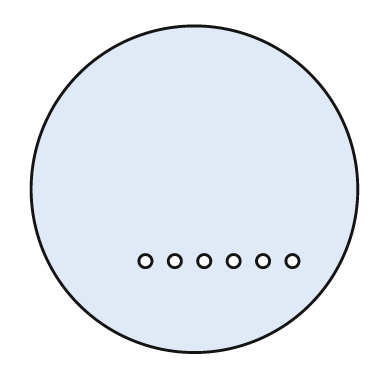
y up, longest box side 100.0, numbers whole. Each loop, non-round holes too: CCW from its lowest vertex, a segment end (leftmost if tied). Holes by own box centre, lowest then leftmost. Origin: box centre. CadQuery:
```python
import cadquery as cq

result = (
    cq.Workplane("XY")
    .moveTo(0.0, 0.0)
    .circle(50.0)
    .moveTo(-15.0, -22.0)
    .circle(2.0)
    .moveTo(-6.0, -22.0)
    .circle(2.0)
    .moveTo(3.0, -22.0)
    .circle(2.0)
    .moveTo(12.0, -22.0)
    .circle(2.0)
    .moveTo(21.0, -22.0)
    .circle(2.0)
    .moveTo(30.0, -22.0)
    .circle(2.0)
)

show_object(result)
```